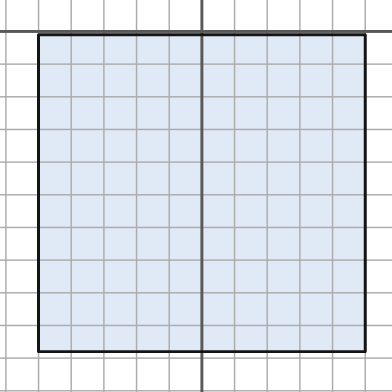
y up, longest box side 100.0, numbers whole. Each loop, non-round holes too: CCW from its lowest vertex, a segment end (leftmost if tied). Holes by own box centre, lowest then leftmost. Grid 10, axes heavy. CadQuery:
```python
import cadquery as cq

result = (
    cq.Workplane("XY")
    .moveTo(-50.0, -98.0)
    .lineTo(50.0, -98.0)
    .lineTo(50.0, -1.0)
    .lineTo(-50.0, -1.0)
    .close()
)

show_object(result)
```